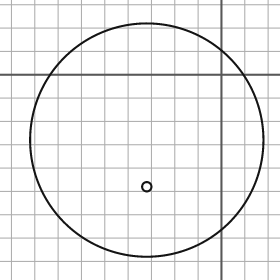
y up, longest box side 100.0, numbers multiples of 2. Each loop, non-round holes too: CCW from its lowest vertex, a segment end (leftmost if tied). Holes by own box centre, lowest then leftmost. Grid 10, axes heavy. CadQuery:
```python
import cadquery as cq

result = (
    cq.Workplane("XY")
    .moveTo(-32.0, -28.0)
    .circle(50.0)
    .moveTo(-32.0, -48.0)
    .circle(2.0)
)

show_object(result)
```